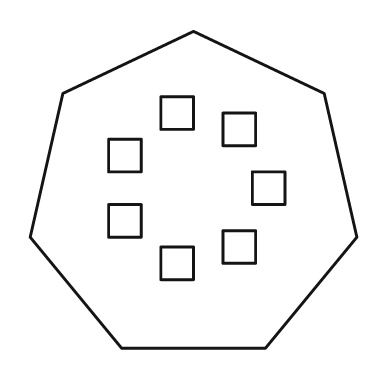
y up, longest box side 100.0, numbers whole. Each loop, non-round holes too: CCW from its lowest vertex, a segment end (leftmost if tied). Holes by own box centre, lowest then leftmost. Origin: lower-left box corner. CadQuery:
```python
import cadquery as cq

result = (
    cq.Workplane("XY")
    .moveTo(28.0, 0.0)
    .lineTo(72.0, 0.0)
    .lineTo(100.0, 34.0)
    .lineTo(90.0, 78.0)
    .lineTo(50.0, 97.0)
    .lineTo(10.0, 78.0)
    .lineTo(0.0, 34.0)
    .close()
    .moveTo(40.0, 21.0)
    .lineTo(50.0, 21.0)
    .lineTo(50.0, 31.0)
    .lineTo(40.0, 31.0)
    .close()
    .moveTo(59.0, 26.0)
    .lineTo(69.0, 26.0)
    .lineTo(69.0, 36.0)
    .lineTo(59.0, 36.0)
    .close()
    .moveTo(24.0, 34.0)
    .lineTo(34.0, 34.0)
    .lineTo(34.0, 44.0)
    .lineTo(24.0, 44.0)
    .close()
    .moveTo(68.0, 44.0)
    .lineTo(78.0, 44.0)
    .lineTo(78.0, 54.0)
    .lineTo(68.0, 54.0)
    .close()
    .moveTo(24.0, 54.0)
    .lineTo(34.0, 54.0)
    .lineTo(34.0, 64.0)
    .lineTo(24.0, 64.0)
    .close()
    .moveTo(59.0, 62.0)
    .lineTo(69.0, 62.0)
    .lineTo(69.0, 72.0)
    .lineTo(59.0, 72.0)
    .close()
    .moveTo(40.0, 67.0)
    .lineTo(50.0, 67.0)
    .lineTo(50.0, 77.0)
    .lineTo(40.0, 77.0)
    .close()
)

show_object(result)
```